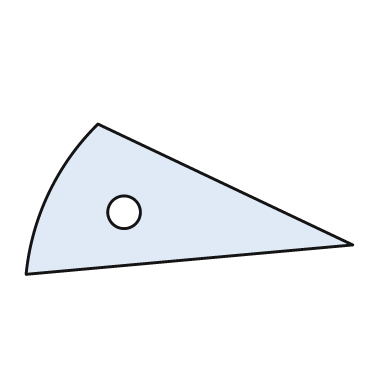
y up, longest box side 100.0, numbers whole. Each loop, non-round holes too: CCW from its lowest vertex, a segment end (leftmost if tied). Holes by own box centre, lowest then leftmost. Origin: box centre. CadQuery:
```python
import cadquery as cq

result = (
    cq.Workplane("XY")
    .moveTo(-50.0, -23.0)
    .lineTo(50.0, -14.0)
    .lineTo(-28.0, 23.0)
    .threePointArc((-43.0, 2.0), (-50.0, -23.0))
    .close()
    .moveTo(-20.0, -4.0)
    .circle(5.0)
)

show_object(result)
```